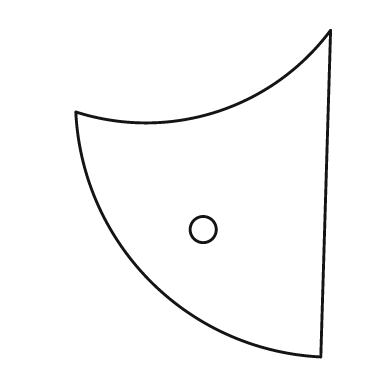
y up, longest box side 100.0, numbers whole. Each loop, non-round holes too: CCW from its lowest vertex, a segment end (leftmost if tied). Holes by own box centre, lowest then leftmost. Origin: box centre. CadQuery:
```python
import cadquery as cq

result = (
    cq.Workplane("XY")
    .moveTo(36.0, -50.0)
    .lineTo(39.0, 50.0)
    .threePointArc((4.0, 25.0), (-39.0, 25.0))
    .threePointArc((-16.0, -27.0), (36.0, -50.0))
    .close()
    .moveTo(0.0, -11.0)
    .circle(4.0)
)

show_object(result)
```